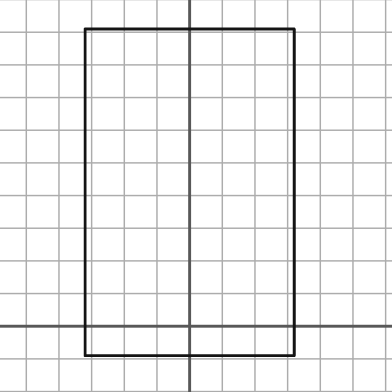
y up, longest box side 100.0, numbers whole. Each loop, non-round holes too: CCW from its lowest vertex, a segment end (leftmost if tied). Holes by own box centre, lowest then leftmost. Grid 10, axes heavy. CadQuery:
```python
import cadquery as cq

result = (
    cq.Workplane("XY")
    .moveTo(-32.0, -9.0)
    .lineTo(32.0, -9.0)
    .lineTo(32.0, 91.0)
    .lineTo(-32.0, 91.0)
    .close()
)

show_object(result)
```